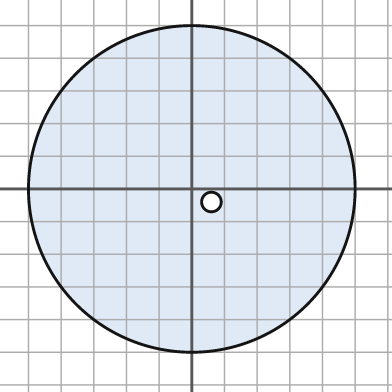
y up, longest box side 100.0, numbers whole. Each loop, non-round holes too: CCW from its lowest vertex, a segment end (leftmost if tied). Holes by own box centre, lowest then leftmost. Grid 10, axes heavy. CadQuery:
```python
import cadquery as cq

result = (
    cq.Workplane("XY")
    .moveTo(0.0, 0.0)
    .circle(50.0)
    .moveTo(6.0, -4.0)
    .circle(3.0)
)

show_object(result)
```